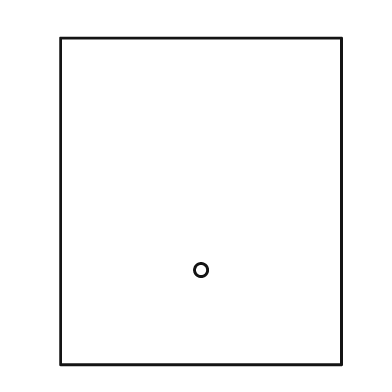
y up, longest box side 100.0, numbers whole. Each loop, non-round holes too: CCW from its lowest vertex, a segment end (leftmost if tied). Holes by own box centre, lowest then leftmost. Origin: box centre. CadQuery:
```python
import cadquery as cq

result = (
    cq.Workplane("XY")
    .moveTo(-43.0, -50.0)
    .lineTo(43.0, -50.0)
    .lineTo(43.0, 50.0)
    .lineTo(-43.0, 50.0)
    .close()
    .moveTo(0.0, -21.0)
    .circle(2.0)
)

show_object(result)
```